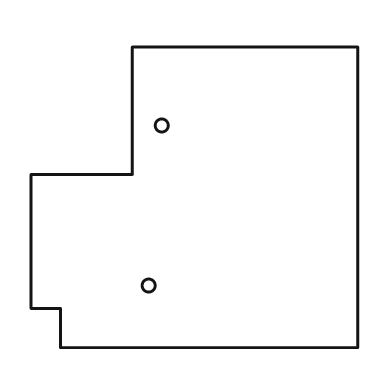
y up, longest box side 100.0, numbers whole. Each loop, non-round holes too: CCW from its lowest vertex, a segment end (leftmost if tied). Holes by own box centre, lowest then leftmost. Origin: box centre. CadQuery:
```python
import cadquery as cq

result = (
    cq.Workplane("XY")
    .moveTo(-41.0, -46.0)
    .lineTo(50.0, -46.0)
    .lineTo(50.0, 46.0)
    .lineTo(-19.0, 46.0)
    .lineTo(-19.0, 7.0)
    .lineTo(-50.0, 7.0)
    .lineTo(-50.0, -34.0)
    .lineTo(-41.0, -34.0)
    .close()
    .moveTo(-14.0, -27.0)
    .circle(2.0)
    .moveTo(-10.0, 22.0)
    .circle(2.0)
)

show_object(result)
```